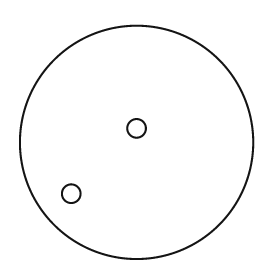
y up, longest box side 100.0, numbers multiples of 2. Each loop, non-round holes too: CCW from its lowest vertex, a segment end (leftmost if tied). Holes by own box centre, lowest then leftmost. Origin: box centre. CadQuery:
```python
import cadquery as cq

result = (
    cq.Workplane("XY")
    .moveTo(0.0, 0.0)
    .circle(50.0)
    .moveTo(-28.0, -22.0)
    .circle(4.0)
    .moveTo(0.0, 6.0)
    .circle(4.0)
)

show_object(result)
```